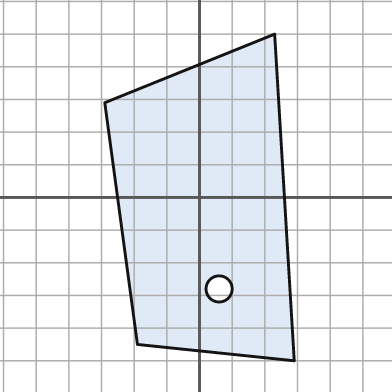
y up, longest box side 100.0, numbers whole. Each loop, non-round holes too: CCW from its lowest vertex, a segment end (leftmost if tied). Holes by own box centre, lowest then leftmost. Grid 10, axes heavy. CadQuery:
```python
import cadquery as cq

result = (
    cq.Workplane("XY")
    .moveTo(29.0, -50.0)
    .lineTo(23.0, 50.0)
    .lineTo(-29.0, 29.0)
    .lineTo(-19.0, -45.0)
    .close()
    .moveTo(6.0, -28.0)
    .circle(4.0)
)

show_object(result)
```